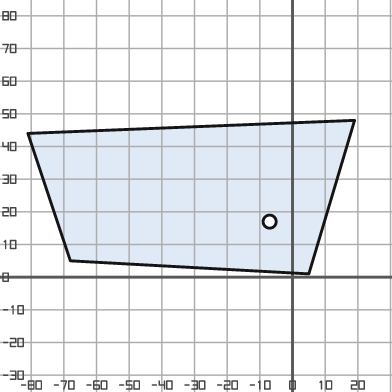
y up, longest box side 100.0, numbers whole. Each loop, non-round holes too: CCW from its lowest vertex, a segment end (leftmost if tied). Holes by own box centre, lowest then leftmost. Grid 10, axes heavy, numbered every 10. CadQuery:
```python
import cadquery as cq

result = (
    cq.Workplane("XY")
    .moveTo(5.0, 1.0)
    .lineTo(19.0, 48.0)
    .lineTo(-81.0, 44.0)
    .lineTo(-68.0, 5.0)
    .close()
    .moveTo(-7.0, 17.0)
    .circle(2.0)
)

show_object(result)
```